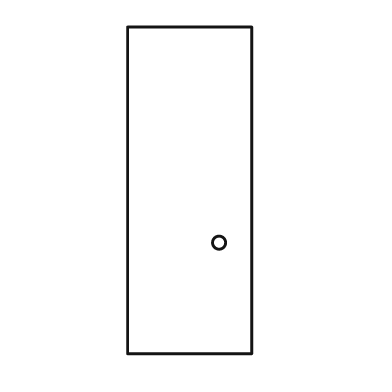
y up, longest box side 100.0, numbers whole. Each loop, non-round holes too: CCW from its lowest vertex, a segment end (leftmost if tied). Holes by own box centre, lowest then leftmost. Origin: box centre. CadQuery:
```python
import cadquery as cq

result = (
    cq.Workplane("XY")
    .moveTo(-19.0, -50.0)
    .lineTo(19.0, -50.0)
    .lineTo(19.0, 50.0)
    .lineTo(-19.0, 50.0)
    .close()
    .moveTo(9.0, -16.0)
    .circle(2.0)
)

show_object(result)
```